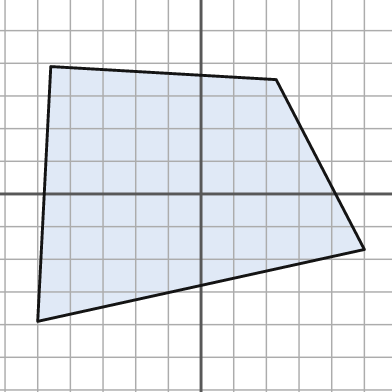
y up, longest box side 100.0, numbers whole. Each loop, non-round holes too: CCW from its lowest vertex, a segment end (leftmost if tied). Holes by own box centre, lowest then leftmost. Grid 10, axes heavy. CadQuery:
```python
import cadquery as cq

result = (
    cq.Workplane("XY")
    .moveTo(-50.0, -39.0)
    .lineTo(50.0, -17.0)
    .lineTo(23.0, 35.0)
    .lineTo(-46.0, 39.0)
    .close()
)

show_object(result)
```